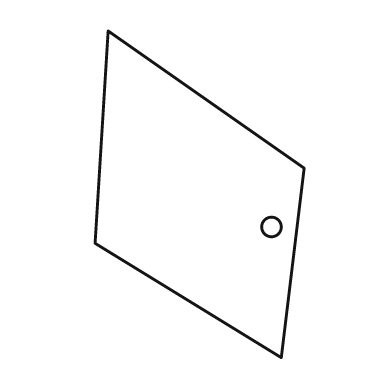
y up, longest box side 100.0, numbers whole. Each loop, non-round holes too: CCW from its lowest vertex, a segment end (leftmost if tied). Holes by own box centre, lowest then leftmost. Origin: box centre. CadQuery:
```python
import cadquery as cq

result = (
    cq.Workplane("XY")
    .moveTo(25.0, -50.0)
    .lineTo(32.0, 8.0)
    .lineTo(-28.0, 50.0)
    .lineTo(-32.0, -15.0)
    .close()
    .moveTo(22.0, -10.0)
    .circle(3.0)
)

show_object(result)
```